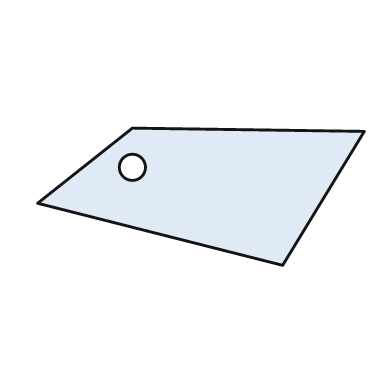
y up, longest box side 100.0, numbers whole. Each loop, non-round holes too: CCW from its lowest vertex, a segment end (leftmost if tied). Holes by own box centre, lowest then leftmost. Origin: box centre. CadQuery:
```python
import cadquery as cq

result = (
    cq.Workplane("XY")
    .moveTo(25.0, -21.0)
    .lineTo(50.0, 20.0)
    .lineTo(-21.0, 21.0)
    .lineTo(-50.0, -2.0)
    .close()
    .moveTo(-21.0, 9.0)
    .circle(4.0)
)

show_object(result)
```